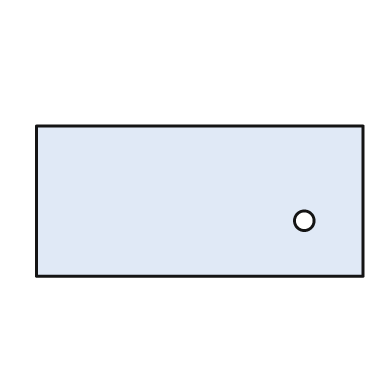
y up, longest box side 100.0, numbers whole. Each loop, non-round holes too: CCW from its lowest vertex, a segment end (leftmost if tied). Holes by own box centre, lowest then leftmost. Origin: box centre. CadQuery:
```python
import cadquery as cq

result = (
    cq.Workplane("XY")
    .moveTo(-50.0, -23.0)
    .lineTo(50.0, -23.0)
    .lineTo(50.0, 23.0)
    .lineTo(-50.0, 23.0)
    .close()
    .moveTo(32.0, -6.0)
    .circle(3.0)
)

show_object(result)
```